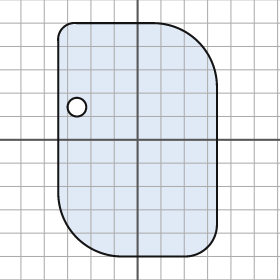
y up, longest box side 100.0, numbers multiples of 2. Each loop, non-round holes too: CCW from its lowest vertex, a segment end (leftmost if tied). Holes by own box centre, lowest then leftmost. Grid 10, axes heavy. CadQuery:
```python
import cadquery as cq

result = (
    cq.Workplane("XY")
    .moveTo(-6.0, -50.0)
    .lineTo(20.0, -50.0)
    .threePointArc((30.0, -46.0), (34.0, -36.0))
    .lineTo(34.0, 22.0)
    .threePointArc((26.0, 42.0), (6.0, 50.0))
    .lineTo(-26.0, 50.0)
    .threePointArc((-32.0, 48.0), (-34.0, 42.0))
    .lineTo(-34.0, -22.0)
    .threePointArc((-26.0, -42.0), (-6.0, -50.0))
    .close()
    .moveTo(-26.0, 14.0)
    .circle(4.0)
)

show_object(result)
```